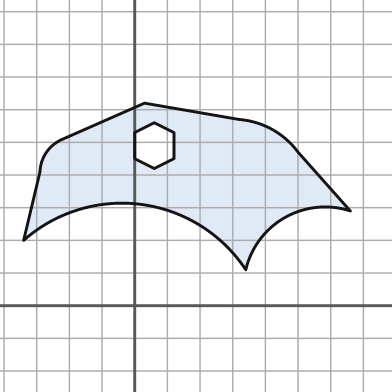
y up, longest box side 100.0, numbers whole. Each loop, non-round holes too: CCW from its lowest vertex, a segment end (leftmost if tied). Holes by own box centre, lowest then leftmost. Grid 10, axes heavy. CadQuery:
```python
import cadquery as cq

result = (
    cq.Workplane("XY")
    .moveTo(34.0, 11.0)
    .threePointArc((46.0, 27.0), (66.0, 29.0))
    .lineTo(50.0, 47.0)
    .threePointArc((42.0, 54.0), (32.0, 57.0))
    .lineTo(3.0, 62.0)
    .lineTo(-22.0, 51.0)
    .threePointArc((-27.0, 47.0), (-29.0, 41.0))
    .lineTo(-34.0, 20.0)
    .threePointArc((2.0, 31.0), (34.0, 11.0))
    .close()
    .moveTo(6.0, 42.0)
    .lineTo(12.0, 45.0)
    .lineTo(12.0, 53.0)
    .lineTo(6.0, 56.0)
    .lineTo(0.0, 53.0)
    .lineTo(0.0, 45.0)
    .close()
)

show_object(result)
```